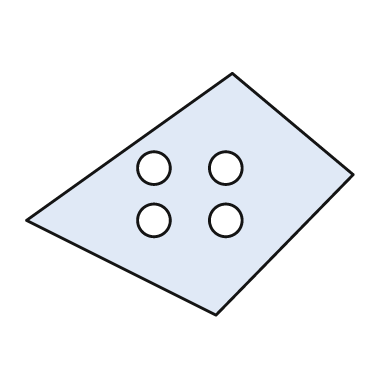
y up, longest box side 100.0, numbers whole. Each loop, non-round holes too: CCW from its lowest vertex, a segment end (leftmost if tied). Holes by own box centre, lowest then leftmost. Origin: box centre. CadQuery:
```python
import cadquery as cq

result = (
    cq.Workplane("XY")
    .moveTo(8.0, -37.0)
    .lineTo(50.0, 6.0)
    .lineTo(13.0, 37.0)
    .lineTo(-50.0, -8.0)
    .close()
    .moveTo(-11.0, -8.0)
    .circle(5.0)
    .moveTo(11.0, -8.0)
    .circle(5.0)
    .moveTo(-11.0, 8.0)
    .circle(5.0)
    .moveTo(11.0, 8.0)
    .circle(5.0)
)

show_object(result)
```